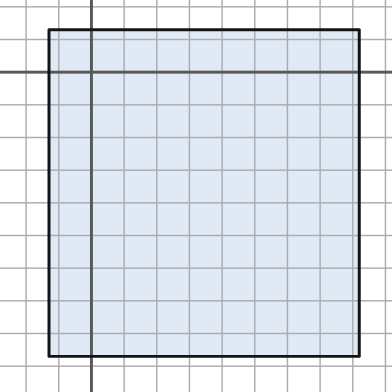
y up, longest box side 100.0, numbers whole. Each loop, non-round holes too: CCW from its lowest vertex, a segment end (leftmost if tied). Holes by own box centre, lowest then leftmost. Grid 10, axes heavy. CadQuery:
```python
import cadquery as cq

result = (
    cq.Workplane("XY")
    .moveTo(-13.0, -87.0)
    .lineTo(82.0, -87.0)
    .lineTo(82.0, 13.0)
    .lineTo(-13.0, 13.0)
    .close()
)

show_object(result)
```